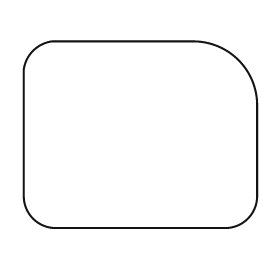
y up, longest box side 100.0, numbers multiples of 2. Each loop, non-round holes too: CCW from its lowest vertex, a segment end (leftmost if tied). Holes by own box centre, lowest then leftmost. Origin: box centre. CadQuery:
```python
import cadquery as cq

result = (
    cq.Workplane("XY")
    .moveTo(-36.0, -40.0)
    .lineTo(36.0, -40.0)
    .threePointArc((46.0, -36.0), (50.0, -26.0))
    .lineTo(50.0, 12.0)
    .threePointArc((42.0, 32.0), (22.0, 40.0))
    .lineTo(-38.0, 40.0)
    .threePointArc((-46.0, 36.0), (-50.0, 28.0))
    .lineTo(-50.0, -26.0)
    .threePointArc((-46.0, -36.0), (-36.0, -40.0))
    .close()
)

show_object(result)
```